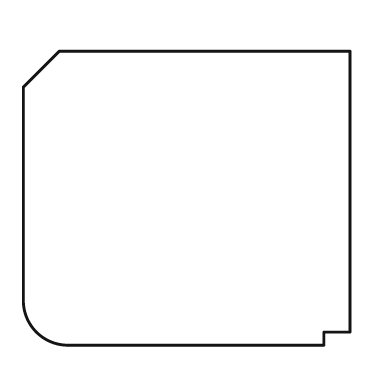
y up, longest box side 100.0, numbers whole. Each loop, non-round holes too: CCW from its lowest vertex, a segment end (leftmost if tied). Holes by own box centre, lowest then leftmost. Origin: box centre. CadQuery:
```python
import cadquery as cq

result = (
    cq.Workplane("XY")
    .moveTo(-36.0, -45.0)
    .lineTo(42.0, -45.0)
    .lineTo(42.0, -41.0)
    .lineTo(50.0, -41.0)
    .lineTo(50.0, 45.0)
    .lineTo(-39.0, 45.0)
    .lineTo(-50.0, 34.0)
    .lineTo(-50.0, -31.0)
    .threePointArc((-46.0, -41.0), (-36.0, -45.0))
    .close()
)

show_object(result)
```